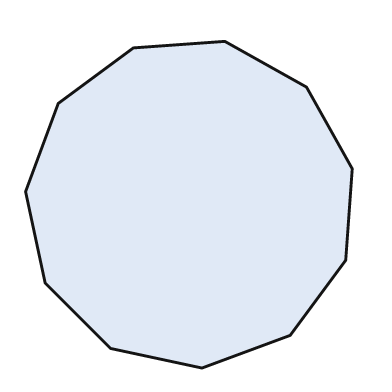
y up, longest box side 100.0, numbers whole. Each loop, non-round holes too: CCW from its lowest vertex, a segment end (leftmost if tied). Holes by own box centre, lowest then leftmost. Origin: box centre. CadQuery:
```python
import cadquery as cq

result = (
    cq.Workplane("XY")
    .moveTo(4.0, -50.0)
    .lineTo(31.0, -40.0)
    .lineTo(48.0, -17.0)
    .lineTo(50.0, 11.0)
    .lineTo(36.0, 36.0)
    .lineTo(11.0, 50.0)
    .lineTo(-17.0, 48.0)
    .lineTo(-40.0, 31.0)
    .lineTo(-50.0, 4.0)
    .lineTo(-44.0, -24.0)
    .lineTo(-24.0, -44.0)
    .close()
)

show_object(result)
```